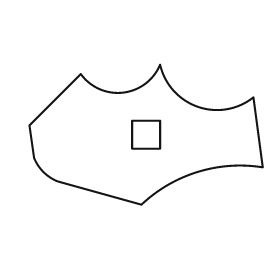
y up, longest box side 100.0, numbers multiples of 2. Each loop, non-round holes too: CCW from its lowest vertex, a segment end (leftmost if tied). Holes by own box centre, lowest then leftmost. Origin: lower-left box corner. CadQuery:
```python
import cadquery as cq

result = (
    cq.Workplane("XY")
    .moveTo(48.0, 0.0)
    .threePointArc((72.0, 14.0), (100.0, 16.0))
    .lineTo(96.0, 46.0)
    .threePointArc((72.0, 42.0), (56.0, 60.0))
    .threePointArc((40.0, 48.0), (22.0, 56.0))
    .lineTo(0.0, 34.0)
    .lineTo(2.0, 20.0)
    .threePointArc((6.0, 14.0), (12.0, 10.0))
    .close()
    .moveTo(44.0, 24.0)
    .lineTo(56.0, 24.0)
    .lineTo(56.0, 36.0)
    .lineTo(44.0, 36.0)
    .close()
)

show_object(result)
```